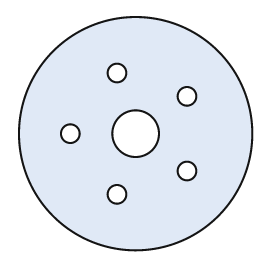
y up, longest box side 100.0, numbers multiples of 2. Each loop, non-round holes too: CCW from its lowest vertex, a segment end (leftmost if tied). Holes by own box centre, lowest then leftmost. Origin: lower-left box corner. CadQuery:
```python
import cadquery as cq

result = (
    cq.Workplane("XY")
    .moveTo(50.0, 50.0)
    .circle(50.0)
    .moveTo(42.0, 24.0)
    .circle(4.0)
    .moveTo(72.0, 34.0)
    .circle(4.0)
    .moveTo(22.0, 50.0)
    .circle(4.0)
    .moveTo(50.0, 50.0)
    .circle(10.0)
    .moveTo(72.0, 66.0)
    .circle(4.0)
    .moveTo(42.0, 76.0)
    .circle(4.0)
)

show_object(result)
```